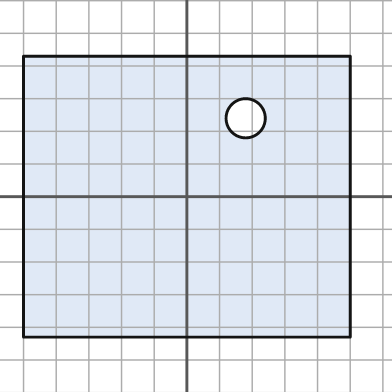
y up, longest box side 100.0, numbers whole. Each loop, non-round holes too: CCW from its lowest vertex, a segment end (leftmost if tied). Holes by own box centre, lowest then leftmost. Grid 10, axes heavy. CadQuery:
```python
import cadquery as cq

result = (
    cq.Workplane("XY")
    .moveTo(-50.0, -43.0)
    .lineTo(50.0, -43.0)
    .lineTo(50.0, 43.0)
    .lineTo(-50.0, 43.0)
    .close()
    .moveTo(18.0, 24.0)
    .circle(6.0)
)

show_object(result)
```